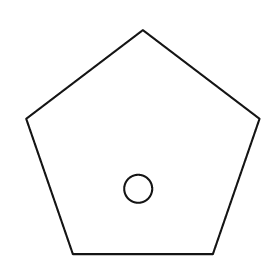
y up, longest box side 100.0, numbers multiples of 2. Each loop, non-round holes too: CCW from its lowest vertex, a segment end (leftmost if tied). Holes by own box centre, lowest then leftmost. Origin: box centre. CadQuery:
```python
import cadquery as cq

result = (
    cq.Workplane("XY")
    .moveTo(-30.0, -48.0)
    .lineTo(30.0, -48.0)
    .lineTo(50.0, 10.0)
    .lineTo(0.0, 48.0)
    .lineTo(-50.0, 10.0)
    .close()
    .moveTo(-2.0, -20.0)
    .circle(6.0)
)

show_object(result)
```